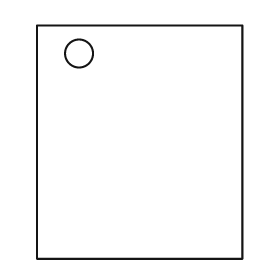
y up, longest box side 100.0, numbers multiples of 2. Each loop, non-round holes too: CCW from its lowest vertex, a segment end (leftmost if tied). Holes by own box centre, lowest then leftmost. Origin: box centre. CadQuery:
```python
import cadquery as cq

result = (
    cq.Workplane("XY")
    .moveTo(-44.0, -50.0)
    .lineTo(44.0, -50.0)
    .lineTo(44.0, 50.0)
    .lineTo(-44.0, 50.0)
    .close()
    .moveTo(-26.0, 38.0)
    .circle(6.0)
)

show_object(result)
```